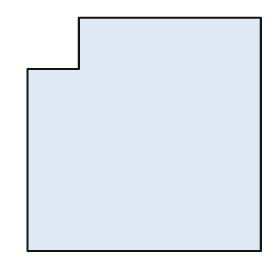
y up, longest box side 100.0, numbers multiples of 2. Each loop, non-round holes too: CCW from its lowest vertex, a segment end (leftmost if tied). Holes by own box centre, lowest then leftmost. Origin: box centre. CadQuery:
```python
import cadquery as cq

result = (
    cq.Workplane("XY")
    .moveTo(-50.0, -50.0)
    .lineTo(50.0, -50.0)
    .lineTo(50.0, 50.0)
    .lineTo(-28.0, 50.0)
    .lineTo(-28.0, 28.0)
    .lineTo(-50.0, 28.0)
    .close()
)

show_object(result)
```